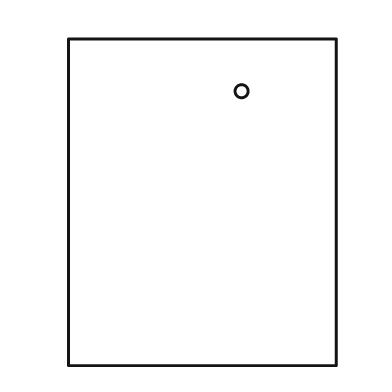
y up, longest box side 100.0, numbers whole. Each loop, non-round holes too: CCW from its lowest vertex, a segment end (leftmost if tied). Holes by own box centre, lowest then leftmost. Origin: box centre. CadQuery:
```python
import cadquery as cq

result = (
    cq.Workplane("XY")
    .moveTo(-41.0, -50.0)
    .lineTo(41.0, -50.0)
    .lineTo(41.0, 50.0)
    .lineTo(-41.0, 50.0)
    .close()
    .moveTo(12.0, 34.0)
    .circle(2.0)
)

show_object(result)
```